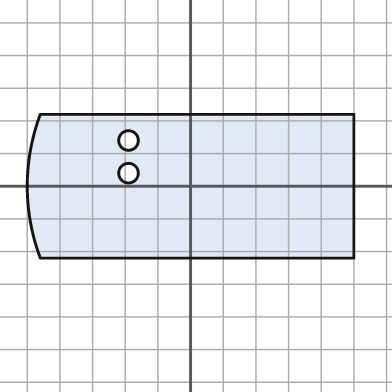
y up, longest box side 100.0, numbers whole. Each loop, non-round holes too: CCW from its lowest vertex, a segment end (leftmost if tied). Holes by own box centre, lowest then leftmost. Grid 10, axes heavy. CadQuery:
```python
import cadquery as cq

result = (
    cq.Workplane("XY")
    .moveTo(-46.0, -22.0)
    .lineTo(50.0, -22.0)
    .lineTo(50.0, 22.0)
    .lineTo(-46.0, 22.0)
    .threePointArc((-50.0, 0.0), (-46.0, -22.0))
    .close()
    .moveTo(-19.0, 4.0)
    .circle(3.0)
    .moveTo(-19.0, 14.0)
    .circle(3.0)
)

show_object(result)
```